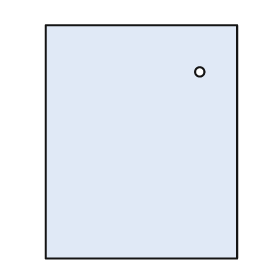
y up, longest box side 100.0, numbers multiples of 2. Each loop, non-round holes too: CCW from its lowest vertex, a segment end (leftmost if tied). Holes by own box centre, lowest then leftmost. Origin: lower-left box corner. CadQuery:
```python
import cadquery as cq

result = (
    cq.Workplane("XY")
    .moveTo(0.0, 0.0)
    .lineTo(82.0, 0.0)
    .lineTo(82.0, 100.0)
    .lineTo(0.0, 100.0)
    .close()
    .moveTo(66.0, 80.0)
    .circle(2.0)
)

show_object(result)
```